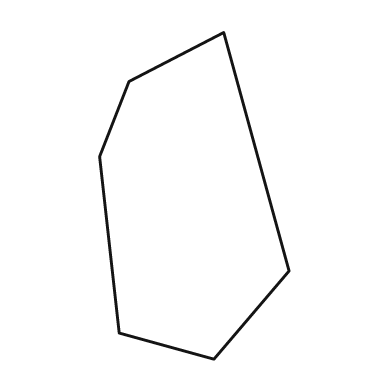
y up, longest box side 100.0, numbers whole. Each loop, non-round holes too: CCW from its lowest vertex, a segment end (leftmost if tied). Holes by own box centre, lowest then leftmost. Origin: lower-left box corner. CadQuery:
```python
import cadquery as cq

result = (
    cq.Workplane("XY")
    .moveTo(35.0, 0.0)
    .lineTo(58.0, 27.0)
    .lineTo(38.0, 100.0)
    .lineTo(9.0, 85.0)
    .lineTo(0.0, 62.0)
    .lineTo(6.0, 8.0)
    .close()
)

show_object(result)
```